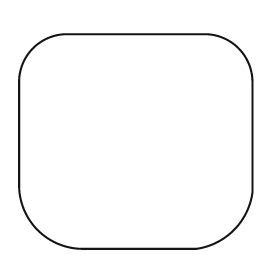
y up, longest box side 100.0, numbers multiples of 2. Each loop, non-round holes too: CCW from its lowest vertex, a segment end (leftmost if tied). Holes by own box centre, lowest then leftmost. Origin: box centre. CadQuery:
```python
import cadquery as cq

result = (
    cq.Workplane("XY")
    .moveTo(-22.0, -46.0)
    .lineTo(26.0, -46.0)
    .threePointArc((42.0, -38.0), (50.0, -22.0))
    .lineTo(50.0, 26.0)
    .threePointArc((44.0, 40.0), (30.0, 46.0))
    .lineTo(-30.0, 46.0)
    .threePointArc((-44.0, 40.0), (-50.0, 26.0))
    .lineTo(-50.0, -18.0)
    .threePointArc((-42.0, -38.0), (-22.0, -46.0))
    .close()
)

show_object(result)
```